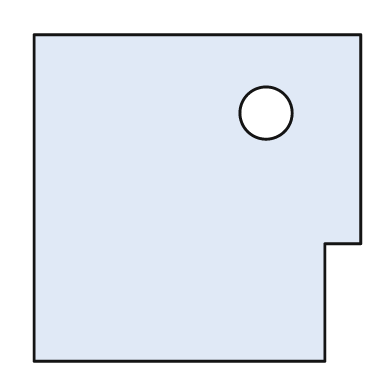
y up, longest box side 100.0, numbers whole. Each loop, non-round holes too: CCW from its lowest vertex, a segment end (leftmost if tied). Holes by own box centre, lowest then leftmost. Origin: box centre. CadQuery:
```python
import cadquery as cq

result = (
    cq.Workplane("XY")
    .moveTo(-50.0, -50.0)
    .lineTo(39.0, -50.0)
    .lineTo(39.0, -14.0)
    .lineTo(50.0, -14.0)
    .lineTo(50.0, 50.0)
    .lineTo(-50.0, 50.0)
    .close()
    .moveTo(21.0, 26.0)
    .circle(8.0)
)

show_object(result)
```